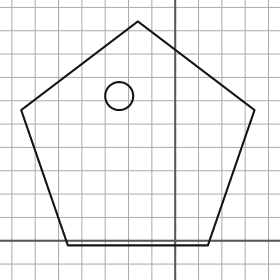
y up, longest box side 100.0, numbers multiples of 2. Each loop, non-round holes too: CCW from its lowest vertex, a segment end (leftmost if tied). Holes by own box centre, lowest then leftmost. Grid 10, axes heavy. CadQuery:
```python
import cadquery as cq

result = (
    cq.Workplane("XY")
    .moveTo(-46.0, -2.0)
    .lineTo(14.0, -2.0)
    .lineTo(34.0, 56.0)
    .lineTo(-16.0, 94.0)
    .lineTo(-66.0, 56.0)
    .close()
    .moveTo(-24.0, 62.0)
    .circle(6.0)
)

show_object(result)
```